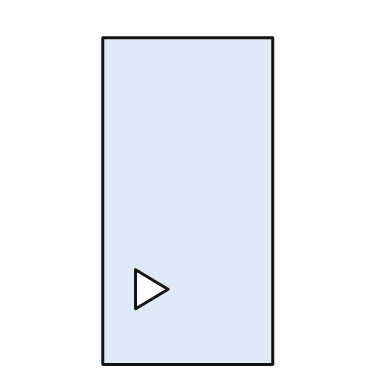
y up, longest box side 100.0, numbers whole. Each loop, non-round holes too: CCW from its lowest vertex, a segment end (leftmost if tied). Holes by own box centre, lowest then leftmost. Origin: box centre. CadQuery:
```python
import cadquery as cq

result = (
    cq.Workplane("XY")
    .moveTo(-26.0, -50.0)
    .lineTo(26.0, -50.0)
    .lineTo(26.0, 50.0)
    .lineTo(-26.0, 50.0)
    .close()
    .moveTo(-16.0, -33.0)
    .lineTo(-6.0, -27.0)
    .lineTo(-16.0, -21.0)
    .close()
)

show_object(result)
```